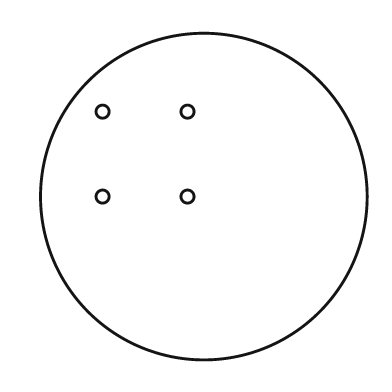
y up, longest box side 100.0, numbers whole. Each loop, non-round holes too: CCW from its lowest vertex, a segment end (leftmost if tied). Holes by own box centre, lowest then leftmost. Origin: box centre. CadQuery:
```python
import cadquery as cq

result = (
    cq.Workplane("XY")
    .moveTo(0.0, 0.0)
    .circle(50.0)
    .moveTo(-31.0, 0.0)
    .circle(2.0)
    .moveTo(-5.0, 0.0)
    .circle(2.0)
    .moveTo(-31.0, 26.0)
    .circle(2.0)
    .moveTo(-5.0, 26.0)
    .circle(2.0)
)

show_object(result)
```